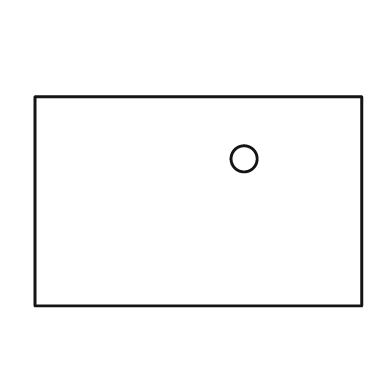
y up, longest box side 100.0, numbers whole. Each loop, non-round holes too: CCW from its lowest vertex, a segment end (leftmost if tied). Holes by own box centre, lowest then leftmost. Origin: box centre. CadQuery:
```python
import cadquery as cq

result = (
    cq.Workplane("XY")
    .moveTo(-50.0, -32.0)
    .lineTo(50.0, -32.0)
    .lineTo(50.0, 32.0)
    .lineTo(-50.0, 32.0)
    .close()
    .moveTo(14.0, 13.0)
    .circle(4.0)
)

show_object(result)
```